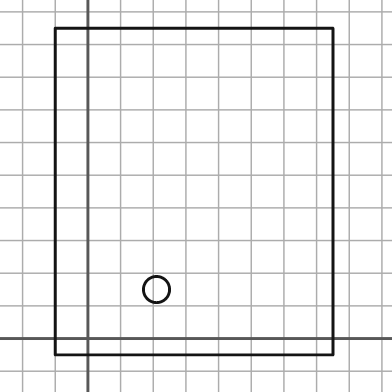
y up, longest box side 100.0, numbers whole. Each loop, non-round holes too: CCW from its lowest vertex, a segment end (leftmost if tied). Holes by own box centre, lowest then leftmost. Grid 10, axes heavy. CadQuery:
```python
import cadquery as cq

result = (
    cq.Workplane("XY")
    .moveTo(-10.0, -5.0)
    .lineTo(75.0, -5.0)
    .lineTo(75.0, 95.0)
    .lineTo(-10.0, 95.0)
    .close()
    .moveTo(21.0, 15.0)
    .circle(4.0)
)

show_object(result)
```